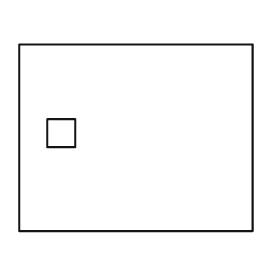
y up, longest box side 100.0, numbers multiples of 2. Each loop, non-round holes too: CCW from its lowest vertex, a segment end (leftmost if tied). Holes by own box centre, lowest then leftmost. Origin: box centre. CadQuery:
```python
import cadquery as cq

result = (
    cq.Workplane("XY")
    .moveTo(-50.0, -40.0)
    .lineTo(50.0, -40.0)
    .lineTo(50.0, 40.0)
    .lineTo(-50.0, 40.0)
    .close()
    .moveTo(-38.0, -4.0)
    .lineTo(-26.0, -4.0)
    .lineTo(-26.0, 8.0)
    .lineTo(-38.0, 8.0)
    .close()
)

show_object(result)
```